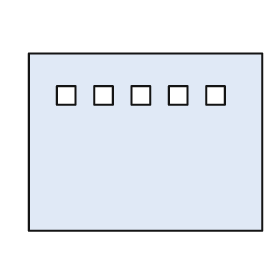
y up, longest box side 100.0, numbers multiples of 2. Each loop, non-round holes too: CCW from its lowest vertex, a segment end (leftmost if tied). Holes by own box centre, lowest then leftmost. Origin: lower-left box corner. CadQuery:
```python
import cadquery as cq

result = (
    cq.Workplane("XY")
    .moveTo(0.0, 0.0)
    .lineTo(100.0, 0.0)
    .lineTo(100.0, 76.0)
    .lineTo(0.0, 76.0)
    .close()
    .moveTo(12.0, 54.0)
    .lineTo(20.0, 54.0)
    .lineTo(20.0, 62.0)
    .lineTo(12.0, 62.0)
    .close()
    .moveTo(28.0, 54.0)
    .lineTo(36.0, 54.0)
    .lineTo(36.0, 62.0)
    .lineTo(28.0, 62.0)
    .close()
    .moveTo(44.0, 54.0)
    .lineTo(52.0, 54.0)
    .lineTo(52.0, 62.0)
    .lineTo(44.0, 62.0)
    .close()
    .moveTo(60.0, 54.0)
    .lineTo(68.0, 54.0)
    .lineTo(68.0, 62.0)
    .lineTo(60.0, 62.0)
    .close()
    .moveTo(76.0, 54.0)
    .lineTo(84.0, 54.0)
    .lineTo(84.0, 62.0)
    .lineTo(76.0, 62.0)
    .close()
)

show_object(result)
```